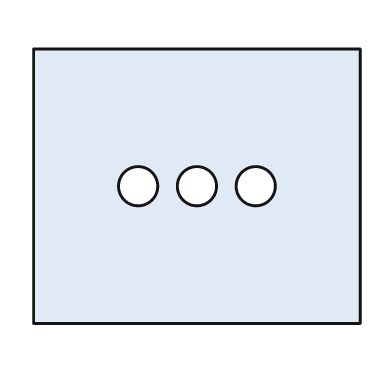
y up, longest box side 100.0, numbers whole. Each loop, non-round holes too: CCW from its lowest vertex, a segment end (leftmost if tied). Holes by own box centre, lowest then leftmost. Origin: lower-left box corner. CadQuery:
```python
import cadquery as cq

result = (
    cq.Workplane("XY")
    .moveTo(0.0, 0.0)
    .lineTo(100.0, 0.0)
    .lineTo(100.0, 84.0)
    .lineTo(0.0, 84.0)
    .close()
    .moveTo(32.0, 42.0)
    .circle(6.0)
    .moveTo(50.0, 42.0)
    .circle(6.0)
    .moveTo(68.0, 42.0)
    .circle(6.0)
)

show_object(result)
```